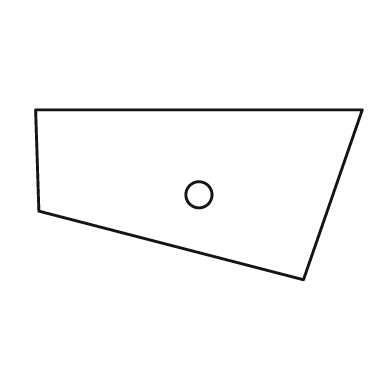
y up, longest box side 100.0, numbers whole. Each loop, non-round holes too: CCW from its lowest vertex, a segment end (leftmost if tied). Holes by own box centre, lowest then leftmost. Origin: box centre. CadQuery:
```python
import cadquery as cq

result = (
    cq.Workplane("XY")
    .moveTo(32.0, -26.0)
    .lineTo(50.0, 26.0)
    .lineTo(-50.0, 26.0)
    .lineTo(-49.0, -5.0)
    .close()
    .moveTo(0.0, 0.0)
    .circle(4.0)
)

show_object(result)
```